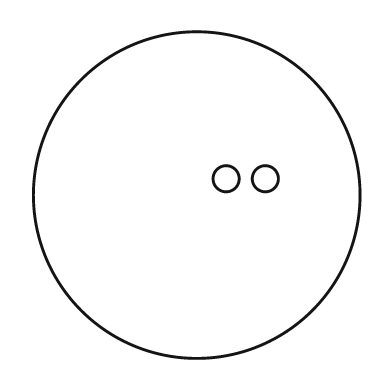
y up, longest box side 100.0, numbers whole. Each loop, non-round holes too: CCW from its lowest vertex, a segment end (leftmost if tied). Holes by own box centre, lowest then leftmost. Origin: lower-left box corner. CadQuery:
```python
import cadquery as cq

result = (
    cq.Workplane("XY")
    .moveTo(50.0, 50.0)
    .circle(50.0)
    .moveTo(59.0, 55.0)
    .circle(4.0)
    .moveTo(71.0, 55.0)
    .circle(4.0)
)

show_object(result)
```